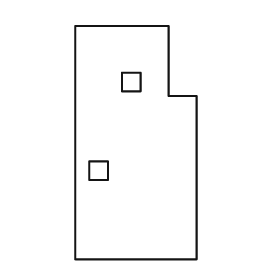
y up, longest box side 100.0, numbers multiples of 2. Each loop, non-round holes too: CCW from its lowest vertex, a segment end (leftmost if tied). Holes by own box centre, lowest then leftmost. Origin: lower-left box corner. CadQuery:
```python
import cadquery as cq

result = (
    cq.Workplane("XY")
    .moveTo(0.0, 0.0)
    .lineTo(52.0, 0.0)
    .lineTo(52.0, 70.0)
    .lineTo(40.0, 70.0)
    .lineTo(40.0, 100.0)
    .lineTo(0.0, 100.0)
    .close()
    .moveTo(6.0, 34.0)
    .lineTo(14.0, 34.0)
    .lineTo(14.0, 42.0)
    .lineTo(6.0, 42.0)
    .close()
    .moveTo(20.0, 72.0)
    .lineTo(28.0, 72.0)
    .lineTo(28.0, 80.0)
    .lineTo(20.0, 80.0)
    .close()
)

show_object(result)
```